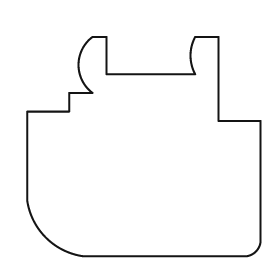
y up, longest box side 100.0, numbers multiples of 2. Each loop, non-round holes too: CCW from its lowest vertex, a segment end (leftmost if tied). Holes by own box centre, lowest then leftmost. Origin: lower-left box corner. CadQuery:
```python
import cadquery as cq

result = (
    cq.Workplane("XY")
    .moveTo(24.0, 0.0)
    .lineTo(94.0, 0.0)
    .threePointArc((98.0, 2.0), (100.0, 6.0))
    .lineTo(100.0, 58.0)
    .lineTo(82.0, 58.0)
    .lineTo(82.0, 94.0)
    .lineTo(72.0, 94.0)
    .threePointArc((70.0, 86.0), (72.0, 78.0))
    .lineTo(34.0, 78.0)
    .lineTo(34.0, 94.0)
    .lineTo(28.0, 94.0)
    .threePointArc((22.0, 82.0), (28.0, 70.0))
    .lineTo(18.0, 70.0)
    .lineTo(18.0, 62.0)
    .lineTo(0.0, 62.0)
    .lineTo(0.0, 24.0)
    .threePointArc((8.0, 8.0), (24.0, 0.0))
    .close()
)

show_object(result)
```